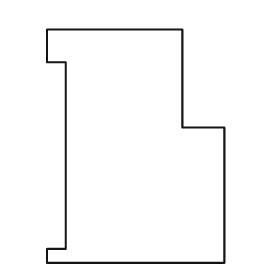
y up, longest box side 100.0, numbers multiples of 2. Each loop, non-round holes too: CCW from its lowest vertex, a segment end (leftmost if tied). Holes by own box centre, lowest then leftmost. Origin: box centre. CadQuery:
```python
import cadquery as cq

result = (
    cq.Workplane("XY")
    .moveTo(-38.0, -50.0)
    .lineTo(38.0, -50.0)
    .lineTo(38.0, 8.0)
    .lineTo(20.0, 8.0)
    .lineTo(20.0, 50.0)
    .lineTo(-38.0, 50.0)
    .lineTo(-38.0, 36.0)
    .lineTo(-30.0, 36.0)
    .lineTo(-30.0, -44.0)
    .lineTo(-38.0, -44.0)
    .close()
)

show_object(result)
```